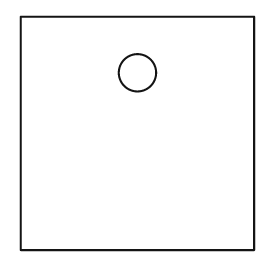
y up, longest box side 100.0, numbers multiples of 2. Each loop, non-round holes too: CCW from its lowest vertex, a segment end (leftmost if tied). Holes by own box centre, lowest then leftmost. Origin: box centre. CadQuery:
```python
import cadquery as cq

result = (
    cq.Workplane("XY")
    .moveTo(-50.0, -50.0)
    .lineTo(50.0, -50.0)
    .lineTo(50.0, 50.0)
    .lineTo(-50.0, 50.0)
    .close()
    .moveTo(0.0, 26.0)
    .circle(8.0)
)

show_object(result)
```